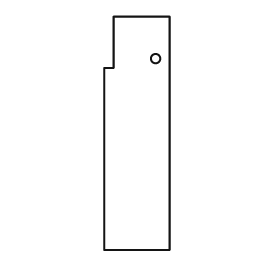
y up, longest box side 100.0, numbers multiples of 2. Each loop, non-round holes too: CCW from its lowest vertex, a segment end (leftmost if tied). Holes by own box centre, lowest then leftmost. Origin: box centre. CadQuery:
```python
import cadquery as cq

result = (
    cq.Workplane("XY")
    .moveTo(-14.0, -50.0)
    .lineTo(14.0, -50.0)
    .lineTo(14.0, 50.0)
    .lineTo(-10.0, 50.0)
    .lineTo(-10.0, 28.0)
    .lineTo(-14.0, 28.0)
    .close()
    .moveTo(8.0, 32.0)
    .circle(2.0)
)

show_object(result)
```